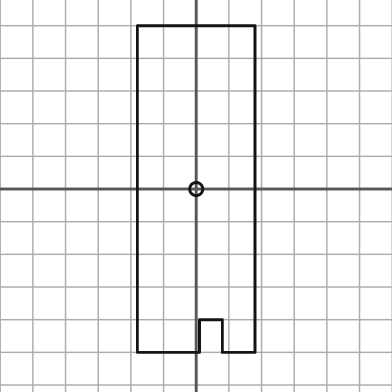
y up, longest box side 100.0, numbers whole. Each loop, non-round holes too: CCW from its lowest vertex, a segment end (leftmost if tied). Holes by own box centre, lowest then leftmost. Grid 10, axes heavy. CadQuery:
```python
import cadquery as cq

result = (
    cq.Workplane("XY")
    .moveTo(-18.0, -50.0)
    .lineTo(1.0, -50.0)
    .lineTo(1.0, -40.0)
    .lineTo(8.0, -40.0)
    .lineTo(8.0, -50.0)
    .lineTo(18.0, -50.0)
    .lineTo(18.0, 50.0)
    .lineTo(-18.0, 50.0)
    .close()
    .moveTo(0.0, 0.0)
    .circle(2.0)
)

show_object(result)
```